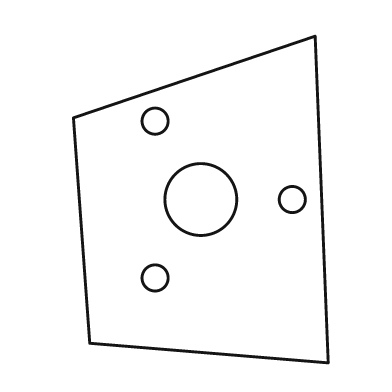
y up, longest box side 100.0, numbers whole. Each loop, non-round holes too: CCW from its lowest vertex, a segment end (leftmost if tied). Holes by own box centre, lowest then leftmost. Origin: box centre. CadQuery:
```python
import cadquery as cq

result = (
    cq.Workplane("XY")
    .moveTo(39.0, -50.0)
    .lineTo(35.0, 50.0)
    .lineTo(-39.0, 25.0)
    .lineTo(-34.0, -44.0)
    .close()
    .moveTo(-14.0, -24.0)
    .circle(4.0)
    .moveTo(0.0, 0.0)
    .circle(11.0)
    .moveTo(28.0, 0.0)
    .circle(4.0)
    .moveTo(-14.0, 24.0)
    .circle(4.0)
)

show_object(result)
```